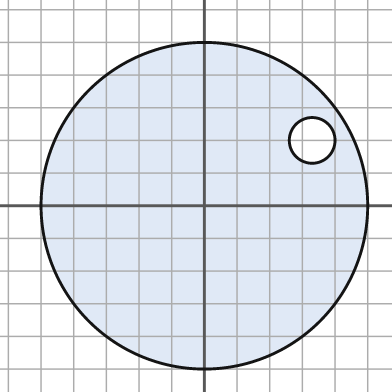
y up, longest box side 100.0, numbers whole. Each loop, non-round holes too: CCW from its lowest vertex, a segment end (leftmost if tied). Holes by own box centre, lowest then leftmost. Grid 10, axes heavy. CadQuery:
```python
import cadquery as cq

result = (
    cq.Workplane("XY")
    .moveTo(0.0, 0.0)
    .circle(50.0)
    .moveTo(33.0, 20.0)
    .circle(7.0)
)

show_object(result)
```